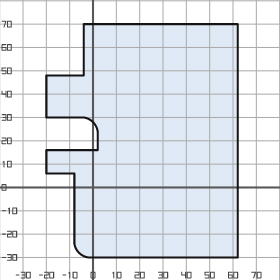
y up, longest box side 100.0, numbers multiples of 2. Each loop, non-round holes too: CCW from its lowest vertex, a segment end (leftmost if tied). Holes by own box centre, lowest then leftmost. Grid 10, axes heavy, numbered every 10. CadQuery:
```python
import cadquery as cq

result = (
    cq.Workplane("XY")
    .moveTo(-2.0, -30.0)
    .lineTo(62.0, -30.0)
    .lineTo(62.0, 70.0)
    .lineTo(-4.0, 70.0)
    .lineTo(-4.0, 48.0)
    .lineTo(-20.0, 48.0)
    .lineTo(-20.0, 30.0)
    .lineTo(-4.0, 30.0)
    .threePointArc((0.0, 28.0), (2.0, 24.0))
    .lineTo(2.0, 16.0)
    .lineTo(-20.0, 16.0)
    .lineTo(-20.0, 6.0)
    .lineTo(-8.0, 6.0)
    .lineTo(-8.0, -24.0)
    .threePointArc((-6.0, -28.0), (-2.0, -30.0))
    .close()
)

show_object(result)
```